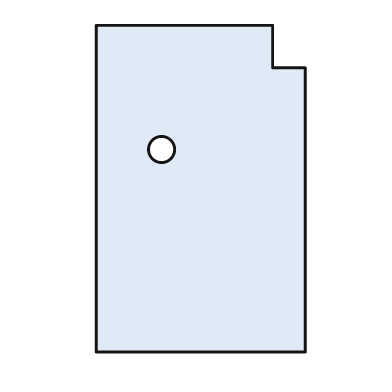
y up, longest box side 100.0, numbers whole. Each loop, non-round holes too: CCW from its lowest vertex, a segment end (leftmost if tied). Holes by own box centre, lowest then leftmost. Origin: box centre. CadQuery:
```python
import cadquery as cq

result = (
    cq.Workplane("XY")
    .moveTo(-32.0, -50.0)
    .lineTo(32.0, -50.0)
    .lineTo(32.0, 37.0)
    .lineTo(22.0, 37.0)
    .lineTo(22.0, 50.0)
    .lineTo(-32.0, 50.0)
    .close()
    .moveTo(-12.0, 12.0)
    .circle(4.0)
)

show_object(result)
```